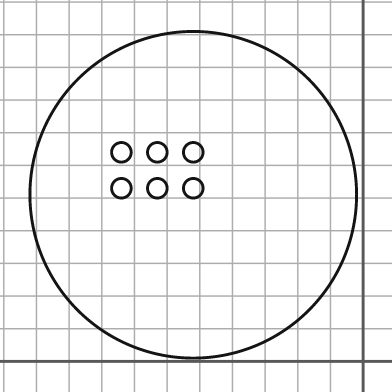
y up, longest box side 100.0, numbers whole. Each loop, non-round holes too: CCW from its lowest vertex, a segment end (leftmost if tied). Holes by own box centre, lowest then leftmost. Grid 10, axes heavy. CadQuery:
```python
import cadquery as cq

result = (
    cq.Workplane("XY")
    .moveTo(-52.0, 51.0)
    .circle(50.0)
    .moveTo(-74.0, 53.0)
    .circle(3.0)
    .moveTo(-63.0, 53.0)
    .circle(3.0)
    .moveTo(-52.0, 53.0)
    .circle(3.0)
    .moveTo(-74.0, 64.0)
    .circle(3.0)
    .moveTo(-63.0, 64.0)
    .circle(3.0)
    .moveTo(-52.0, 64.0)
    .circle(3.0)
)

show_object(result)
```